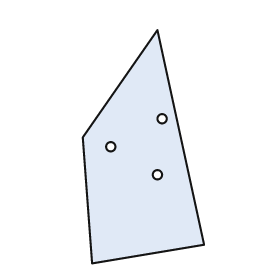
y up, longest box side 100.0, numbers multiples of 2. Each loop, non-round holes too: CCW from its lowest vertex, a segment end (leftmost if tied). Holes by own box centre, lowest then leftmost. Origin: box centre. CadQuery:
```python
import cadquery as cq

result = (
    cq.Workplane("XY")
    .moveTo(-22.0, -50.0)
    .lineTo(26.0, -42.0)
    .lineTo(6.0, 50.0)
    .lineTo(-26.0, 4.0)
    .close()
    .moveTo(6.0, -12.0)
    .circle(2.0)
    .moveTo(-14.0, 0.0)
    .circle(2.0)
    .moveTo(8.0, 12.0)
    .circle(2.0)
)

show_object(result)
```